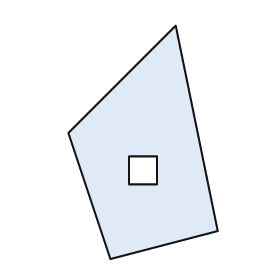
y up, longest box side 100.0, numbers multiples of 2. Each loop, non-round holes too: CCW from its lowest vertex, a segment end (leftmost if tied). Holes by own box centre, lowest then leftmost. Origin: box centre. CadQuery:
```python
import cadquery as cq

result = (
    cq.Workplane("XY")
    .moveTo(-14.0, -50.0)
    .lineTo(32.0, -38.0)
    .lineTo(14.0, 50.0)
    .lineTo(-32.0, 4.0)
    .close()
    .moveTo(-6.0, -18.0)
    .lineTo(6.0, -18.0)
    .lineTo(6.0, -6.0)
    .lineTo(-6.0, -6.0)
    .close()
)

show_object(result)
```